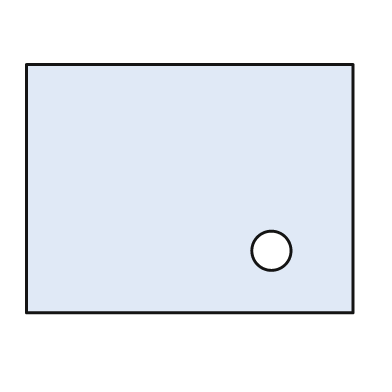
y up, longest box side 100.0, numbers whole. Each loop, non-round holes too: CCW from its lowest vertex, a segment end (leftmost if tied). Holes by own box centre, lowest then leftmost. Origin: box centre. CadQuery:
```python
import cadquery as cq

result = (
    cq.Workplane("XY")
    .moveTo(-50.0, -38.0)
    .lineTo(50.0, -38.0)
    .lineTo(50.0, 38.0)
    .lineTo(-50.0, 38.0)
    .close()
    .moveTo(25.0, -19.0)
    .circle(6.0)
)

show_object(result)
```